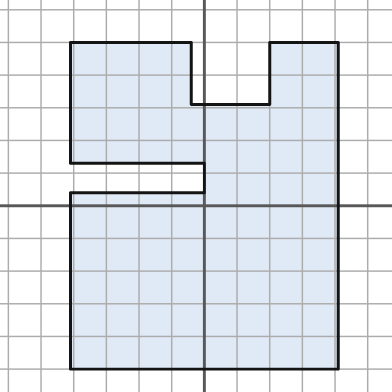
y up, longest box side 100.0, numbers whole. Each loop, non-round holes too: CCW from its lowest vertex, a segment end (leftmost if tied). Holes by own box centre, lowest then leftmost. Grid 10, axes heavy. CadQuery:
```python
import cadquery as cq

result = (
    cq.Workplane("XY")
    .moveTo(-41.0, -50.0)
    .lineTo(41.0, -50.0)
    .lineTo(41.0, 50.0)
    .lineTo(20.0, 50.0)
    .lineTo(20.0, 31.0)
    .lineTo(-4.0, 31.0)
    .lineTo(-4.0, 50.0)
    .lineTo(-41.0, 50.0)
    .lineTo(-41.0, 13.0)
    .lineTo(0.0, 13.0)
    .lineTo(0.0, 4.0)
    .lineTo(-41.0, 4.0)
    .close()
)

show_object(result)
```